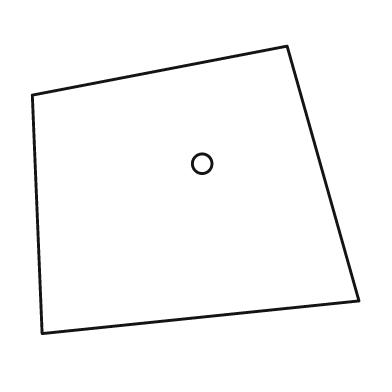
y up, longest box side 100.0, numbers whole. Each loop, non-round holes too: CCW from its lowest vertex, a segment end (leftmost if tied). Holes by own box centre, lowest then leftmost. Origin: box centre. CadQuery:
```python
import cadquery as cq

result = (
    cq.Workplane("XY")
    .moveTo(-47.0, -44.0)
    .lineTo(50.0, -34.0)
    .lineTo(28.0, 44.0)
    .lineTo(-50.0, 29.0)
    .close()
    .moveTo(2.0, 8.0)
    .circle(3.0)
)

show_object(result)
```